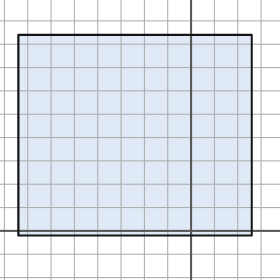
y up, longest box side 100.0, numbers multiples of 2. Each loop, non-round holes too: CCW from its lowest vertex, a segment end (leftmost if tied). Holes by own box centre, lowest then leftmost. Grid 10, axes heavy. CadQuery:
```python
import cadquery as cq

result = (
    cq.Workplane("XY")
    .moveTo(-74.0, -2.0)
    .lineTo(26.0, -2.0)
    .lineTo(26.0, 84.0)
    .lineTo(-74.0, 84.0)
    .close()
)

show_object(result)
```